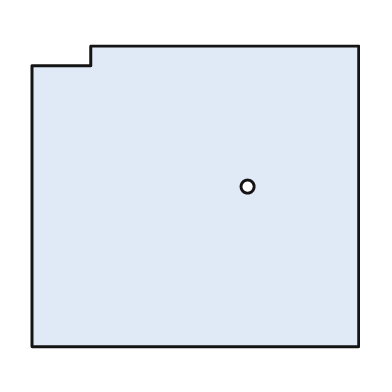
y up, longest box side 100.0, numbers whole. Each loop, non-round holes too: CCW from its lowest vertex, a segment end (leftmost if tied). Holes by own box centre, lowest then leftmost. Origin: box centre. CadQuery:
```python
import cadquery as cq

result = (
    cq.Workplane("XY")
    .moveTo(-50.0, -46.0)
    .lineTo(50.0, -46.0)
    .lineTo(50.0, 46.0)
    .lineTo(-32.0, 46.0)
    .lineTo(-32.0, 40.0)
    .lineTo(-50.0, 40.0)
    .close()
    .moveTo(16.0, 3.0)
    .circle(2.0)
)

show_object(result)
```